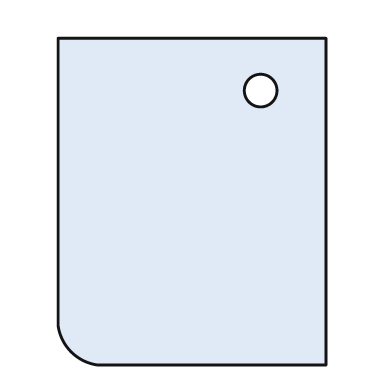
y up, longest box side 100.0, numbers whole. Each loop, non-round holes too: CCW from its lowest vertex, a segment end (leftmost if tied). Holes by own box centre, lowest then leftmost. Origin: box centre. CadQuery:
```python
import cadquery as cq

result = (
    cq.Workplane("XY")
    .moveTo(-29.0, -50.0)
    .lineTo(41.0, -50.0)
    .lineTo(41.0, 50.0)
    .lineTo(-41.0, 50.0)
    .lineTo(-41.0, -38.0)
    .threePointArc((-37.0, -46.0), (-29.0, -50.0))
    .close()
    .moveTo(21.0, 34.0)
    .circle(5.0)
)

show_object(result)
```